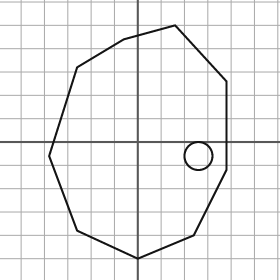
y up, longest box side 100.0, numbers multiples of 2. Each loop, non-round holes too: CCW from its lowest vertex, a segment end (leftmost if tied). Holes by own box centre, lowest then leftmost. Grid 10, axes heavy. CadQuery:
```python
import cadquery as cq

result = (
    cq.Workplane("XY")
    .moveTo(0.0, -50.0)
    .lineTo(24.0, -40.0)
    .lineTo(38.0, -12.0)
    .lineTo(38.0, 26.0)
    .lineTo(16.0, 50.0)
    .lineTo(-6.0, 44.0)
    .lineTo(-26.0, 32.0)
    .lineTo(-38.0, -6.0)
    .lineTo(-26.0, -38.0)
    .close()
    .moveTo(26.0, -6.0)
    .circle(6.0)
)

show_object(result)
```